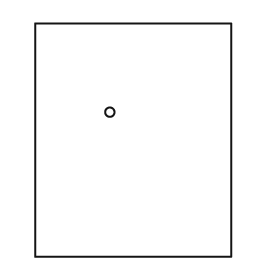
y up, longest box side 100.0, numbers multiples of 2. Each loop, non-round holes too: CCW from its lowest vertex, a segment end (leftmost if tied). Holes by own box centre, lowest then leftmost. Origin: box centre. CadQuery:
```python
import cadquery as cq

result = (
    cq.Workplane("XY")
    .moveTo(-42.0, -50.0)
    .lineTo(42.0, -50.0)
    .lineTo(42.0, 50.0)
    .lineTo(-42.0, 50.0)
    .close()
    .moveTo(-10.0, 12.0)
    .circle(2.0)
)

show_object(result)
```